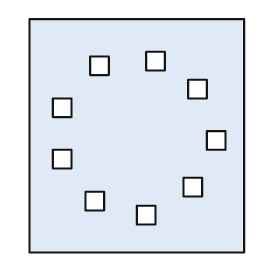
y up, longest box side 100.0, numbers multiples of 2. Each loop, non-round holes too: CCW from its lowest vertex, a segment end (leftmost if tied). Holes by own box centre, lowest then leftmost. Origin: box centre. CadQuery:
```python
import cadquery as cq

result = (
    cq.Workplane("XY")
    .moveTo(-46.0, -50.0)
    .lineTo(46.0, -50.0)
    .lineTo(46.0, 50.0)
    .lineTo(-46.0, 50.0)
    .close()
    .moveTo(0.0, -38.0)
    .lineTo(8.0, -38.0)
    .lineTo(8.0, -30.0)
    .lineTo(0.0, -30.0)
    .close()
    .moveTo(-22.0, -32.0)
    .lineTo(-14.0, -32.0)
    .lineTo(-14.0, -24.0)
    .lineTo(-22.0, -24.0)
    .close()
    .moveTo(20.0, -26.0)
    .lineTo(28.0, -26.0)
    .lineTo(28.0, -18.0)
    .lineTo(20.0, -18.0)
    .close()
    .moveTo(-36.0, -14.0)
    .lineTo(-28.0, -14.0)
    .lineTo(-28.0, -6.0)
    .lineTo(-36.0, -6.0)
    .close()
    .moveTo(30.0, -6.0)
    .lineTo(38.0, -6.0)
    .lineTo(38.0, 2.0)
    .lineTo(30.0, 2.0)
    .close()
    .moveTo(-36.0, 8.0)
    .lineTo(-28.0, 8.0)
    .lineTo(-28.0, 16.0)
    .lineTo(-36.0, 16.0)
    .close()
    .moveTo(22.0, 16.0)
    .lineTo(30.0, 16.0)
    .lineTo(30.0, 24.0)
    .lineTo(22.0, 24.0)
    .close()
    .moveTo(-20.0, 26.0)
    .lineTo(-12.0, 26.0)
    .lineTo(-12.0, 34.0)
    .lineTo(-20.0, 34.0)
    .close()
    .moveTo(4.0, 28.0)
    .lineTo(12.0, 28.0)
    .lineTo(12.0, 36.0)
    .lineTo(4.0, 36.0)
    .close()
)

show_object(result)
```